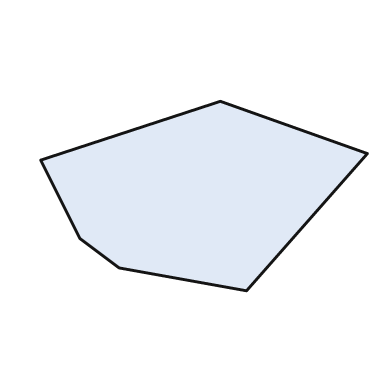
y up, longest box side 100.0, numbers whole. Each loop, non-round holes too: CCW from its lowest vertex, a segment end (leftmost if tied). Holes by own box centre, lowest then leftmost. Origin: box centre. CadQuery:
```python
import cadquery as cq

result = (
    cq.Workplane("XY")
    .moveTo(13.0, -29.0)
    .lineTo(50.0, 13.0)
    .lineTo(5.0, 29.0)
    .lineTo(-50.0, 11.0)
    .lineTo(-38.0, -13.0)
    .lineTo(-26.0, -22.0)
    .close()
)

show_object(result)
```